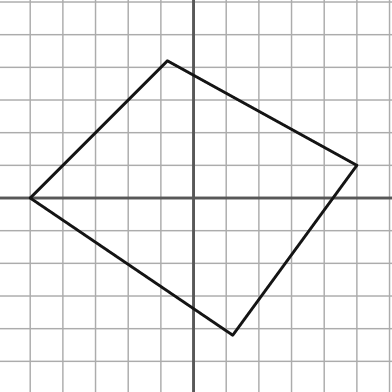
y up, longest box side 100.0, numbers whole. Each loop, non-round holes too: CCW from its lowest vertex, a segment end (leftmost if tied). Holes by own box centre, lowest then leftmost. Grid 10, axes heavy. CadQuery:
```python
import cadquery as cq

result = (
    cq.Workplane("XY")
    .moveTo(12.0, -42.0)
    .lineTo(50.0, 10.0)
    .lineTo(-8.0, 42.0)
    .lineTo(-50.0, 0.0)
    .close()
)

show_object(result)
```